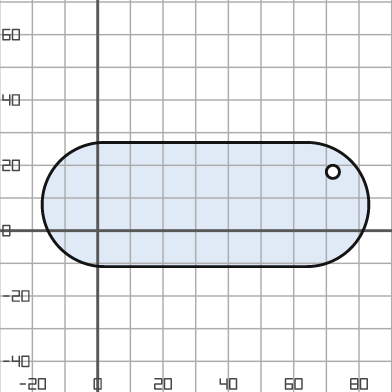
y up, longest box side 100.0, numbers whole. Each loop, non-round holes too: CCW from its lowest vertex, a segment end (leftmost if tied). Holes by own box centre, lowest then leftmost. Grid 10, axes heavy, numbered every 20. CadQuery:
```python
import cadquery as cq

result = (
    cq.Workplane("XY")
    .moveTo(2.0, -11.0)
    .lineTo(64.0, -11.0)
    .threePointArc((83.0, 8.0), (64.0, 27.0))
    .lineTo(2.0, 27.0)
    .threePointArc((-17.0, 8.0), (2.0, -11.0))
    .close()
    .moveTo(72.0, 18.0)
    .circle(2.0)
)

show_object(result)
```